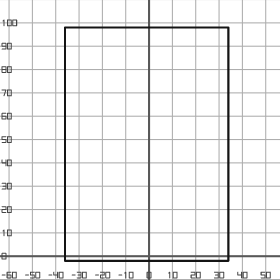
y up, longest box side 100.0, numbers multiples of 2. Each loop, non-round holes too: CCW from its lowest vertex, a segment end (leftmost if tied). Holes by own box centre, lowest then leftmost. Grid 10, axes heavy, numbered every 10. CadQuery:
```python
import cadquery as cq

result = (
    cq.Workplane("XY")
    .moveTo(-36.0, -2.0)
    .lineTo(34.0, -2.0)
    .lineTo(34.0, 98.0)
    .lineTo(-36.0, 98.0)
    .close()
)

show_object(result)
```